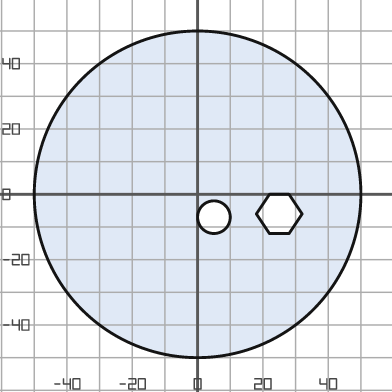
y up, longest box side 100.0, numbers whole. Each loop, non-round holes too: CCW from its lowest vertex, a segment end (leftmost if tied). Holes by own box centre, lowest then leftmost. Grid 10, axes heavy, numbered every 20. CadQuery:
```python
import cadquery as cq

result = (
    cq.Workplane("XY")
    .moveTo(0.0, 0.0)
    .circle(50.0)
    .moveTo(5.0, -7.0)
    .circle(5.0)
    .moveTo(22.0, -12.0)
    .lineTo(28.0, -12.0)
    .lineTo(32.0, -6.0)
    .lineTo(28.0, 0.0)
    .lineTo(22.0, 0.0)
    .lineTo(18.0, -6.0)
    .close()
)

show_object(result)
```